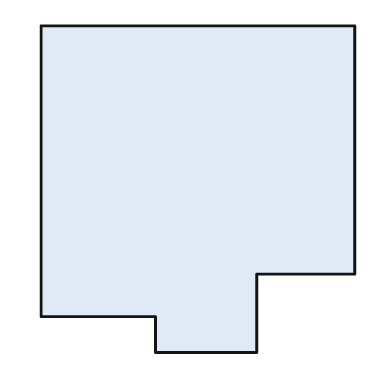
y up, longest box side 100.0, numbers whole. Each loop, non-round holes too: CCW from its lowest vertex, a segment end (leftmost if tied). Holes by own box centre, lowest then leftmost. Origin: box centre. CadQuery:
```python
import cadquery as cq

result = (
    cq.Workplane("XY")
    .moveTo(-13.0, -50.0)
    .lineTo(18.0, -50.0)
    .lineTo(18.0, -26.0)
    .lineTo(48.0, -26.0)
    .lineTo(48.0, 50.0)
    .lineTo(-48.0, 50.0)
    .lineTo(-48.0, -39.0)
    .lineTo(-13.0, -39.0)
    .close()
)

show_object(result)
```